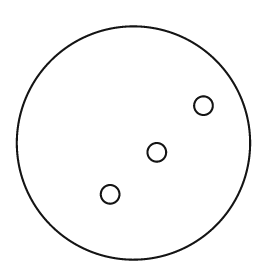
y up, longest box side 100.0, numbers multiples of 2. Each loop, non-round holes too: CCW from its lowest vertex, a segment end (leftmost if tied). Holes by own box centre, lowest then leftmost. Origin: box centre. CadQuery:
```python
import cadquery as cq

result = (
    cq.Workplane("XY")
    .moveTo(0.0, 0.0)
    .circle(50.0)
    .moveTo(-10.0, -22.0)
    .circle(4.0)
    .moveTo(10.0, -4.0)
    .circle(4.0)
    .moveTo(30.0, 16.0)
    .circle(4.0)
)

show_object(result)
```